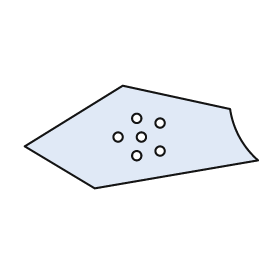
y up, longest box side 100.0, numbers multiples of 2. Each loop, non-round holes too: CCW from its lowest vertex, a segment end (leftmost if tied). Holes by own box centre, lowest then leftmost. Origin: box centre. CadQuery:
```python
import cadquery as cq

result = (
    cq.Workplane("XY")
    .moveTo(-20.0, -22.0)
    .lineTo(50.0, -10.0)
    .threePointArc((42.0, 0.0), (38.0, 12.0))
    .lineTo(-8.0, 22.0)
    .lineTo(-50.0, -4.0)
    .close()
    .moveTo(-2.0, -8.0)
    .circle(2.0)
    .moveTo(8.0, -6.0)
    .circle(2.0)
    .moveTo(-10.0, 0.0)
    .circle(2.0)
    .moveTo(0.0, 0.0)
    .circle(2.0)
    .moveTo(8.0, 6.0)
    .circle(2.0)
    .moveTo(-2.0, 8.0)
    .circle(2.0)
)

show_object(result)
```